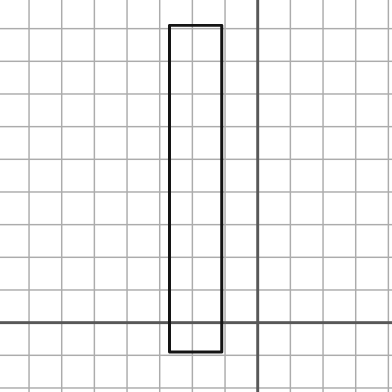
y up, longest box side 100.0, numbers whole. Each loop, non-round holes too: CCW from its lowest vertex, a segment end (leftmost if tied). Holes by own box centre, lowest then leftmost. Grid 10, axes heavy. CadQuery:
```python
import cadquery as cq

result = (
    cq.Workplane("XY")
    .moveTo(-27.0, -9.0)
    .lineTo(-11.0, -9.0)
    .lineTo(-11.0, 91.0)
    .lineTo(-27.0, 91.0)
    .close()
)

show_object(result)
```